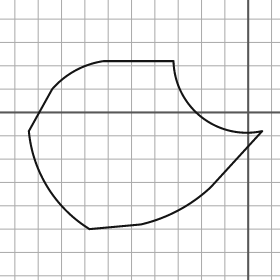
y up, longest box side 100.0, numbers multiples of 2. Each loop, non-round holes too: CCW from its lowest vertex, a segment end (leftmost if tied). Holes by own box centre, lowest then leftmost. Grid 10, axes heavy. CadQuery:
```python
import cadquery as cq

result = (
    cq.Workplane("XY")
    .moveTo(-68.0, -50.0)
    .lineTo(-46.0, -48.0)
    .threePointArc((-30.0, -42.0), (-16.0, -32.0))
    .lineTo(6.0, -8.0)
    .threePointArc((-20.0, -2.0), (-32.0, 22.0))
    .lineTo(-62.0, 22.0)
    .threePointArc((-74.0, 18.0), (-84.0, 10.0))
    .lineTo(-94.0, -8.0)
    .threePointArc((-86.0, -32.0), (-68.0, -50.0))
    .close()
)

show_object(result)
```